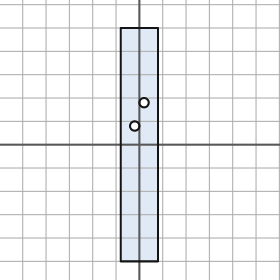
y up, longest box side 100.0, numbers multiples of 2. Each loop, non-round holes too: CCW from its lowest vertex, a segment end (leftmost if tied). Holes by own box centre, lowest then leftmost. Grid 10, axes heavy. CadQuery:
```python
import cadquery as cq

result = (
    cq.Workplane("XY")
    .moveTo(-8.0, -50.0)
    .lineTo(8.0, -50.0)
    .lineTo(8.0, 50.0)
    .lineTo(-8.0, 50.0)
    .close()
    .moveTo(-2.0, 8.0)
    .circle(2.0)
    .moveTo(2.0, 18.0)
    .circle(2.0)
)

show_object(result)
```